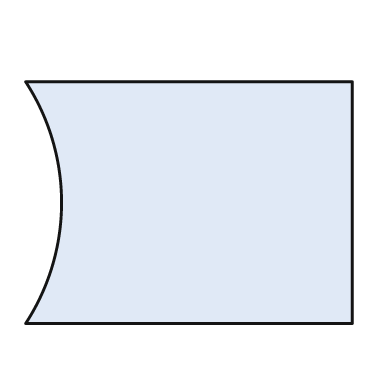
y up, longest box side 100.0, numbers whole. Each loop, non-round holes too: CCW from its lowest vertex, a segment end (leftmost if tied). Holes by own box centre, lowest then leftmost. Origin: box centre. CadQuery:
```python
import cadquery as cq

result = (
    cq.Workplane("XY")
    .moveTo(-50.0, -37.0)
    .lineTo(50.0, -37.0)
    .lineTo(50.0, 37.0)
    .lineTo(-50.0, 37.0)
    .threePointArc((-39.0, 0.0), (-50.0, -37.0))
    .close()
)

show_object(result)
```